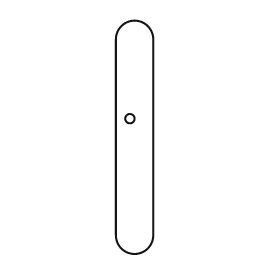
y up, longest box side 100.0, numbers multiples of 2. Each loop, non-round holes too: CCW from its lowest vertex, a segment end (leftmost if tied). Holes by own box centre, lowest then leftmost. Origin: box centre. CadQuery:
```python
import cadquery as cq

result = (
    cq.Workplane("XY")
    .moveTo(-8.0, -42.0)
    .threePointArc((0.0, -50.0), (8.0, -42.0))
    .lineTo(8.0, 42.0)
    .threePointArc((0.0, 50.0), (-8.0, 42.0))
    .close()
    .moveTo(-2.0, 8.0)
    .circle(2.0)
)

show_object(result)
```